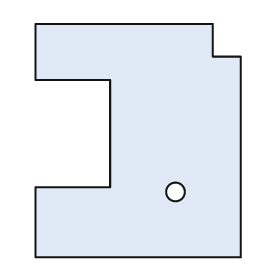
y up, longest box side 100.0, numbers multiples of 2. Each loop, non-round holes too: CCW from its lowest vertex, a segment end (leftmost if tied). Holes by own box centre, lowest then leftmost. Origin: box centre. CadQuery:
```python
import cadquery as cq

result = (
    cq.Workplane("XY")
    .moveTo(-44.0, -50.0)
    .lineTo(44.0, -50.0)
    .lineTo(44.0, 36.0)
    .lineTo(32.0, 36.0)
    .lineTo(32.0, 50.0)
    .lineTo(-44.0, 50.0)
    .lineTo(-44.0, 26.0)
    .lineTo(-12.0, 26.0)
    .lineTo(-12.0, -20.0)
    .lineTo(-44.0, -20.0)
    .close()
    .moveTo(16.0, -22.0)
    .circle(4.0)
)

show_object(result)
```